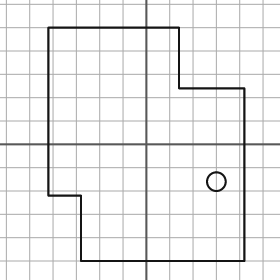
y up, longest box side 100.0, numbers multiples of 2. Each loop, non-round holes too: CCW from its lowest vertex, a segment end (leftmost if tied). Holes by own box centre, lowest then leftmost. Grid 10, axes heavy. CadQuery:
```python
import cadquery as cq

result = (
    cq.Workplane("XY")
    .moveTo(-28.0, -50.0)
    .lineTo(42.0, -50.0)
    .lineTo(42.0, 24.0)
    .lineTo(14.0, 24.0)
    .lineTo(14.0, 50.0)
    .lineTo(-42.0, 50.0)
    .lineTo(-42.0, -22.0)
    .lineTo(-28.0, -22.0)
    .close()
    .moveTo(30.0, -16.0)
    .circle(4.0)
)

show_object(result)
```